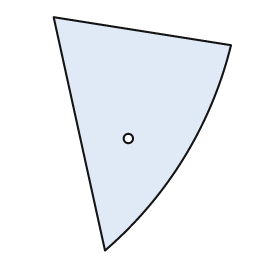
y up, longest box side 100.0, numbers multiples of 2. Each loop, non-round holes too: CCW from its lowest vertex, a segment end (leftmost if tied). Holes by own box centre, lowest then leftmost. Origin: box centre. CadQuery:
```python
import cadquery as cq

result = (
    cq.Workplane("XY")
    .moveTo(-16.0, -50.0)
    .threePointArc((18.0, -10.0), (38.0, 38.0))
    .lineTo(-38.0, 50.0)
    .close()
    .moveTo(-6.0, -2.0)
    .circle(2.0)
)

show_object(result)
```